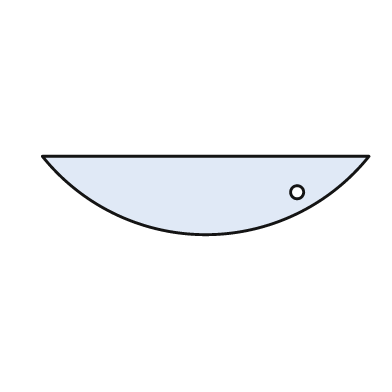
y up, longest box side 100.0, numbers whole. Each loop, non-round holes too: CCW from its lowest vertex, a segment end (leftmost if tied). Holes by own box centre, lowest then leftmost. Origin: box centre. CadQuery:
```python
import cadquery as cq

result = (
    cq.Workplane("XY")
    .moveTo(-50.0, 12.0)
    .threePointArc((0.0, -12.0), (50.0, 12.0))
    .close()
    .moveTo(28.0, 1.0)
    .circle(2.0)
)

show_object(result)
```